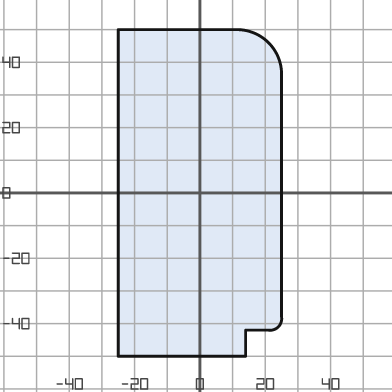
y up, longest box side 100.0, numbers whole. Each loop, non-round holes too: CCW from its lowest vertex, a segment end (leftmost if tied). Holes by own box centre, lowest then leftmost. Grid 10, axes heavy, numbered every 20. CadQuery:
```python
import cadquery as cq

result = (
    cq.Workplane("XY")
    .moveTo(-25.0, -50.0)
    .lineTo(14.0, -50.0)
    .lineTo(14.0, -42.0)
    .lineTo(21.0, -42.0)
    .threePointArc((24.0, -41.0), (25.0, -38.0))
    .lineTo(25.0, 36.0)
    .threePointArc((21.0, 46.0), (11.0, 50.0))
    .lineTo(-25.0, 50.0)
    .close()
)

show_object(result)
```